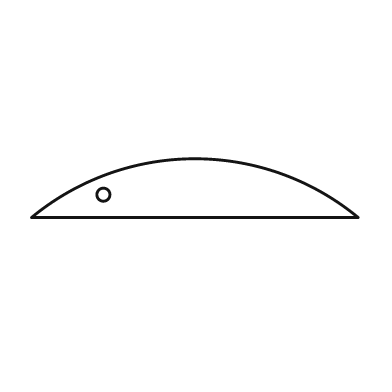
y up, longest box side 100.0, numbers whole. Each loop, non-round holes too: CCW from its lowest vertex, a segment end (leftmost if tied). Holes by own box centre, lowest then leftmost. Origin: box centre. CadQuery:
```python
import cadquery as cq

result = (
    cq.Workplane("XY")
    .moveTo(-50.0, -9.0)
    .lineTo(50.0, -9.0)
    .threePointArc((0.0, 9.0), (-50.0, -9.0))
    .close()
    .moveTo(-28.0, -2.0)
    .circle(2.0)
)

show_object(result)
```